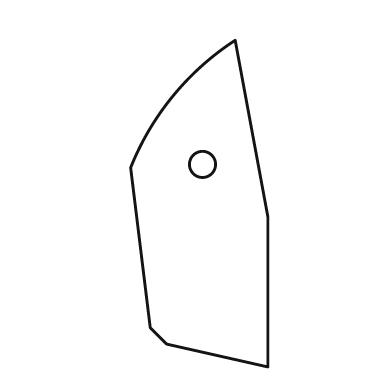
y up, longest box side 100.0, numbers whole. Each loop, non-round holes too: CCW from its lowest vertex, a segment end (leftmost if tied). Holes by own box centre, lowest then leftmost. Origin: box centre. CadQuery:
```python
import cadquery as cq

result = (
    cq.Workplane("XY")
    .moveTo(21.0, -50.0)
    .lineTo(21.0, -4.0)
    .lineTo(11.0, 50.0)
    .threePointArc((-8.0, 33.0), (-21.0, 11.0))
    .lineTo(-15.0, -38.0)
    .lineTo(-10.0, -43.0)
    .close()
    .moveTo(1.0, 12.0)
    .circle(4.0)
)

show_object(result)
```